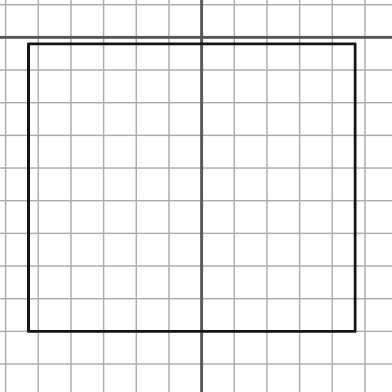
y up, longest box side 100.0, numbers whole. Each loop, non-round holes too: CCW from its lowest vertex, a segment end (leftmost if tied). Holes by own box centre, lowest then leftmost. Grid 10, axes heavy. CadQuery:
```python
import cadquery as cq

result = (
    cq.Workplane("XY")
    .moveTo(-53.0, -90.0)
    .lineTo(47.0, -90.0)
    .lineTo(47.0, -2.0)
    .lineTo(-53.0, -2.0)
    .close()
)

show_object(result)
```